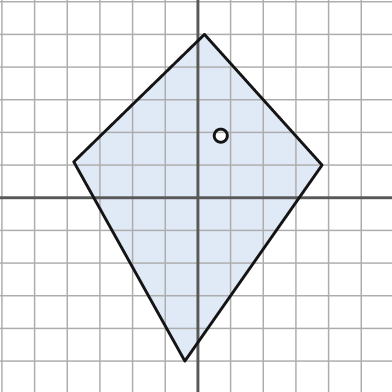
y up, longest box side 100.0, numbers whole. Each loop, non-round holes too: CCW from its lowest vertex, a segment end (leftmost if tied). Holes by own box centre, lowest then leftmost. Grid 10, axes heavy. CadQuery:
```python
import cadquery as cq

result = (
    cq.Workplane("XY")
    .moveTo(-4.0, -50.0)
    .lineTo(38.0, 10.0)
    .lineTo(2.0, 50.0)
    .lineTo(-38.0, 11.0)
    .close()
    .moveTo(7.0, 19.0)
    .circle(2.0)
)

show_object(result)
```